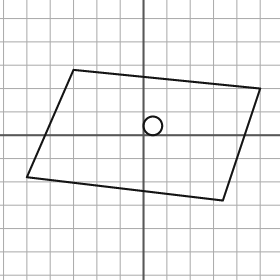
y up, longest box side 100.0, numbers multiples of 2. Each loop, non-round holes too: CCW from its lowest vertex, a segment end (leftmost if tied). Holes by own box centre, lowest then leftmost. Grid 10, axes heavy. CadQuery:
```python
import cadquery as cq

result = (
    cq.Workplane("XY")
    .moveTo(34.0, -28.0)
    .lineTo(50.0, 20.0)
    .lineTo(-30.0, 28.0)
    .lineTo(-50.0, -18.0)
    .close()
    .moveTo(4.0, 4.0)
    .circle(4.0)
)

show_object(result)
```